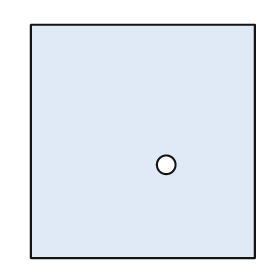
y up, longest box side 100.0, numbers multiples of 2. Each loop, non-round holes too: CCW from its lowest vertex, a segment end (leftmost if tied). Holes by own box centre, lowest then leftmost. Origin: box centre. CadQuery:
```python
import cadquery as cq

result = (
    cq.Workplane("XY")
    .moveTo(-48.0, -50.0)
    .lineTo(48.0, -50.0)
    .lineTo(48.0, 50.0)
    .lineTo(-48.0, 50.0)
    .close()
    .moveTo(10.0, -10.0)
    .circle(4.0)
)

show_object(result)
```